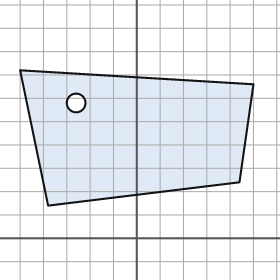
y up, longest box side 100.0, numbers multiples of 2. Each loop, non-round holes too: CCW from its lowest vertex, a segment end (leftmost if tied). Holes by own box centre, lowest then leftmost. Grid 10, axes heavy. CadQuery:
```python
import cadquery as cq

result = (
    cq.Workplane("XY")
    .moveTo(-38.0, 14.0)
    .lineTo(44.0, 24.0)
    .lineTo(50.0, 66.0)
    .lineTo(-50.0, 72.0)
    .close()
    .moveTo(-26.0, 58.0)
    .circle(4.0)
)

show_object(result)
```